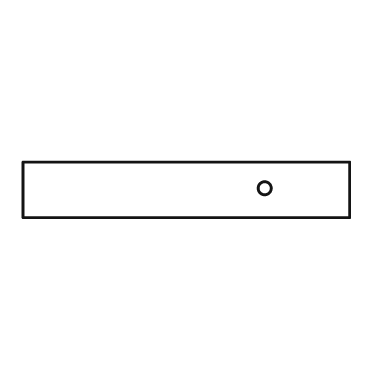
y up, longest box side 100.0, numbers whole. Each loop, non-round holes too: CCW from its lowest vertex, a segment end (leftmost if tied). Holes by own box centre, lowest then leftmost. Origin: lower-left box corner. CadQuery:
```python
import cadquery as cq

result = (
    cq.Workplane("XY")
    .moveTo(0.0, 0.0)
    .lineTo(100.0, 0.0)
    .lineTo(100.0, 17.0)
    .lineTo(0.0, 17.0)
    .close()
    .moveTo(74.0, 9.0)
    .circle(2.0)
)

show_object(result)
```